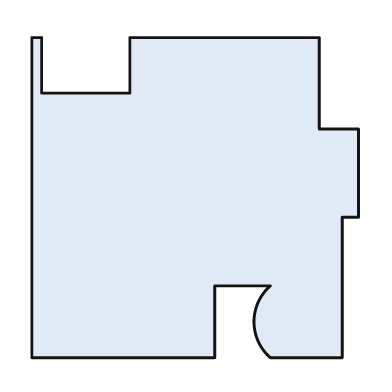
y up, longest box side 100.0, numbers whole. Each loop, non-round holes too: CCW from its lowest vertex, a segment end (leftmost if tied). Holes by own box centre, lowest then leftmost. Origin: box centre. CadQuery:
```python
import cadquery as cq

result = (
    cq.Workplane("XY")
    .moveTo(-50.0, -49.0)
    .lineTo(6.0, -49.0)
    .lineTo(6.0, -27.0)
    .lineTo(23.0, -27.0)
    .threePointArc((18.0, -38.0), (23.0, -49.0))
    .lineTo(45.0, -49.0)
    .lineTo(45.0, -6.0)
    .lineTo(50.0, -6.0)
    .lineTo(50.0, 21.0)
    .lineTo(38.0, 21.0)
    .lineTo(38.0, 49.0)
    .lineTo(-20.0, 49.0)
    .lineTo(-20.0, 32.0)
    .lineTo(-47.0, 32.0)
    .lineTo(-47.0, 49.0)
    .lineTo(-50.0, 49.0)
    .close()
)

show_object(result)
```